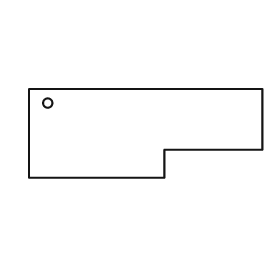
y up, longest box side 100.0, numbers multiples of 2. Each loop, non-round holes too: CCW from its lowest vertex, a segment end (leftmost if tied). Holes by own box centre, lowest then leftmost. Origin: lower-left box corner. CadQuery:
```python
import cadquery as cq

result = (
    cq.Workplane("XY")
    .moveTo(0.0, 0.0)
    .lineTo(58.0, 0.0)
    .lineTo(58.0, 12.0)
    .lineTo(100.0, 12.0)
    .lineTo(100.0, 38.0)
    .lineTo(0.0, 38.0)
    .close()
    .moveTo(8.0, 32.0)
    .circle(2.0)
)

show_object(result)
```